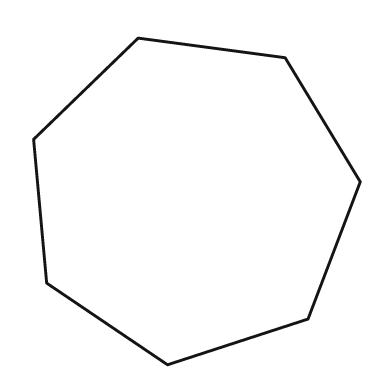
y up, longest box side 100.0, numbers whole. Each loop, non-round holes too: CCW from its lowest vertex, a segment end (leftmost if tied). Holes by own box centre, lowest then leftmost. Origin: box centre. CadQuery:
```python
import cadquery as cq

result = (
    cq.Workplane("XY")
    .moveTo(-9.0, -50.0)
    .lineTo(34.0, -36.0)
    .lineTo(50.0, 6.0)
    .lineTo(27.0, 44.0)
    .lineTo(-18.0, 50.0)
    .lineTo(-50.0, 19.0)
    .lineTo(-46.0, -25.0)
    .close()
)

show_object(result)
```